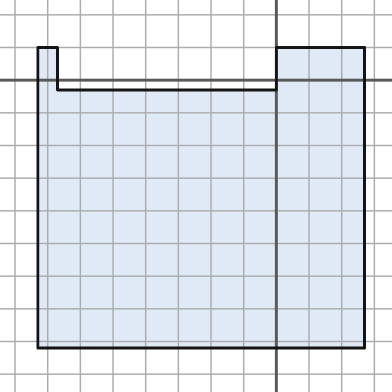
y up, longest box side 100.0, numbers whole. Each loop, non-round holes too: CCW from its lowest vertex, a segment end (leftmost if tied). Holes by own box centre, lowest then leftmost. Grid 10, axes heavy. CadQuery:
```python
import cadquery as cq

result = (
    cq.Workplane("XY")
    .moveTo(-73.0, -82.0)
    .lineTo(27.0, -82.0)
    .lineTo(27.0, 10.0)
    .lineTo(0.0, 10.0)
    .lineTo(0.0, -3.0)
    .lineTo(-67.0, -3.0)
    .lineTo(-67.0, 10.0)
    .lineTo(-73.0, 10.0)
    .close()
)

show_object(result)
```